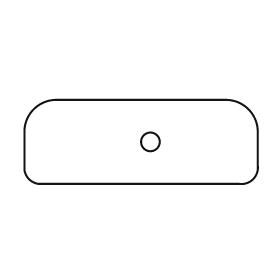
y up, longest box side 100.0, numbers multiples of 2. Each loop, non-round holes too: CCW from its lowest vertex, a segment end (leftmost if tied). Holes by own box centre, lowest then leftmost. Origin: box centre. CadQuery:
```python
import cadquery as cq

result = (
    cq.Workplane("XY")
    .moveTo(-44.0, -18.0)
    .lineTo(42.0, -18.0)
    .threePointArc((48.0, -16.0), (50.0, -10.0))
    .lineTo(50.0, 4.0)
    .threePointArc((46.0, 14.0), (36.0, 18.0))
    .lineTo(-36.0, 18.0)
    .threePointArc((-46.0, 14.0), (-50.0, 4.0))
    .lineTo(-50.0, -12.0)
    .threePointArc((-48.0, -16.0), (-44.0, -18.0))
    .close()
    .moveTo(4.0, 0.0)
    .circle(4.0)
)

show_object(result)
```